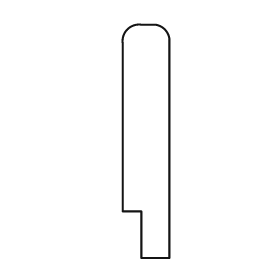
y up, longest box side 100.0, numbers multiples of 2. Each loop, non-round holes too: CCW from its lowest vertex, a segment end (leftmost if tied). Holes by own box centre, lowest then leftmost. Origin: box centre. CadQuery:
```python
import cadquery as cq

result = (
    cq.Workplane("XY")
    .moveTo(-2.0, -50.0)
    .lineTo(10.0, -50.0)
    .lineTo(10.0, 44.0)
    .threePointArc((8.0, 48.0), (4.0, 50.0))
    .lineTo(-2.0, 50.0)
    .threePointArc((-8.0, 48.0), (-10.0, 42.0))
    .lineTo(-10.0, -30.0)
    .lineTo(-2.0, -30.0)
    .close()
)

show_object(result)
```